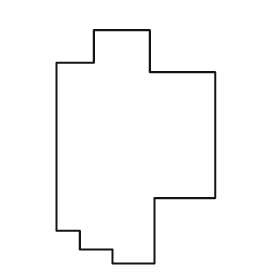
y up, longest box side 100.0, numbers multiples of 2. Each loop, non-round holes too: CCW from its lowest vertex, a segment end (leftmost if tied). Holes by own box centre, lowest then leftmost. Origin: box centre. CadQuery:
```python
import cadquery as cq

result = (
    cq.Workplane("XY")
    .moveTo(-10.0, -50.0)
    .lineTo(8.0, -50.0)
    .lineTo(8.0, -22.0)
    .lineTo(34.0, -22.0)
    .lineTo(34.0, 32.0)
    .lineTo(6.0, 32.0)
    .lineTo(6.0, 50.0)
    .lineTo(-18.0, 50.0)
    .lineTo(-18.0, 36.0)
    .lineTo(-34.0, 36.0)
    .lineTo(-34.0, -36.0)
    .lineTo(-24.0, -36.0)
    .lineTo(-24.0, -44.0)
    .lineTo(-10.0, -44.0)
    .close()
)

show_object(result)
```